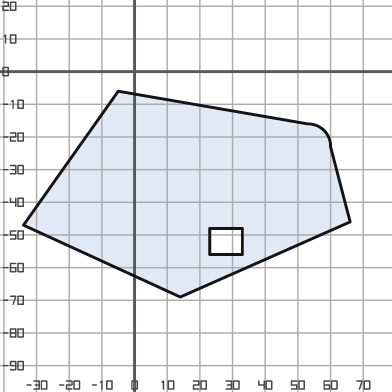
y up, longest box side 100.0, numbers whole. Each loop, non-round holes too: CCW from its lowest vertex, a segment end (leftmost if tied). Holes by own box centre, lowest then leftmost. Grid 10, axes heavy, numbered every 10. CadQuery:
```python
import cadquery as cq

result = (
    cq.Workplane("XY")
    .moveTo(14.0, -69.0)
    .lineTo(66.0, -46.0)
    .lineTo(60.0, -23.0)
    .threePointArc((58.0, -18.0), (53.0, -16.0))
    .lineTo(-5.0, -6.0)
    .lineTo(-34.0, -47.0)
    .close()
    .moveTo(23.0, -56.0)
    .lineTo(33.0, -56.0)
    .lineTo(33.0, -48.0)
    .lineTo(23.0, -48.0)
    .close()
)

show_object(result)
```